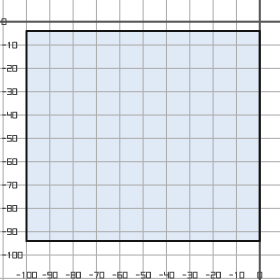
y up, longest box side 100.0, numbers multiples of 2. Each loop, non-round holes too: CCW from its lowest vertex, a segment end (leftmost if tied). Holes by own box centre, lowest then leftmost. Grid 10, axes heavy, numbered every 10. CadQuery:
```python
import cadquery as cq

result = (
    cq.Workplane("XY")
    .moveTo(-100.0, -94.0)
    .lineTo(0.0, -94.0)
    .lineTo(0.0, -4.0)
    .lineTo(-100.0, -4.0)
    .close()
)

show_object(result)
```